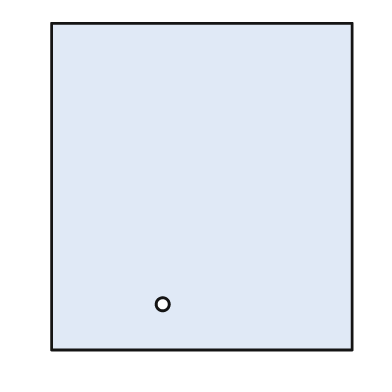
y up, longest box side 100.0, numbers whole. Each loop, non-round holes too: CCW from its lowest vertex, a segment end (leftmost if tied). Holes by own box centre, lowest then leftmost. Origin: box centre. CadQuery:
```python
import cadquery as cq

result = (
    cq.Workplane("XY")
    .moveTo(-46.0, -50.0)
    .lineTo(46.0, -50.0)
    .lineTo(46.0, 50.0)
    .lineTo(-46.0, 50.0)
    .close()
    .moveTo(-12.0, -36.0)
    .circle(2.0)
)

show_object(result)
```